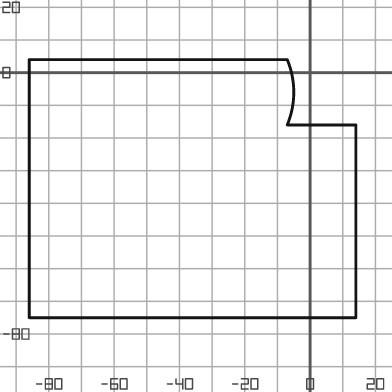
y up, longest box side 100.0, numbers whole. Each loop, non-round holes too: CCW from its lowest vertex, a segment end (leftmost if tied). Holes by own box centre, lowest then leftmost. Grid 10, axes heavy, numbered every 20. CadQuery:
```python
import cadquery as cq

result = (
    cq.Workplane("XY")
    .moveTo(-86.0, -75.0)
    .lineTo(14.0, -75.0)
    .lineTo(14.0, -16.0)
    .lineTo(-7.0, -16.0)
    .threePointArc((-5.0, -6.0), (-7.0, 4.0))
    .lineTo(-86.0, 4.0)
    .close()
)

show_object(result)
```